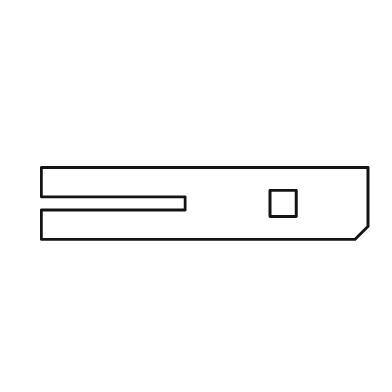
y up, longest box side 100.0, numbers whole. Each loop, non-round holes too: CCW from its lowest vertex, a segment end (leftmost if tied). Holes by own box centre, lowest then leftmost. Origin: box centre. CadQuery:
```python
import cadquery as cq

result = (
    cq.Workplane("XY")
    .moveTo(-50.0, -11.0)
    .lineTo(46.0, -11.0)
    .lineTo(50.0, -7.0)
    .lineTo(50.0, 11.0)
    .lineTo(-50.0, 11.0)
    .lineTo(-50.0, 2.0)
    .lineTo(-6.0, 2.0)
    .lineTo(-6.0, -2.0)
    .lineTo(-50.0, -2.0)
    .close()
    .moveTo(20.0, -4.0)
    .lineTo(28.0, -4.0)
    .lineTo(28.0, 4.0)
    .lineTo(20.0, 4.0)
    .close()
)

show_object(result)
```